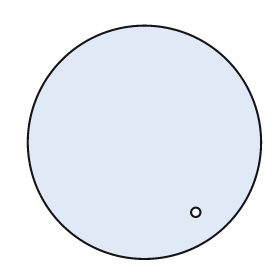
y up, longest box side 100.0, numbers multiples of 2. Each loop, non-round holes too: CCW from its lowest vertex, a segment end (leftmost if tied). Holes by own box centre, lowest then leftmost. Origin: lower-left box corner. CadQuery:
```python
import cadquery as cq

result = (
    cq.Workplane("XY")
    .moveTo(50.0, 50.0)
    .circle(50.0)
    .moveTo(72.0, 20.0)
    .circle(2.0)
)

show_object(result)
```